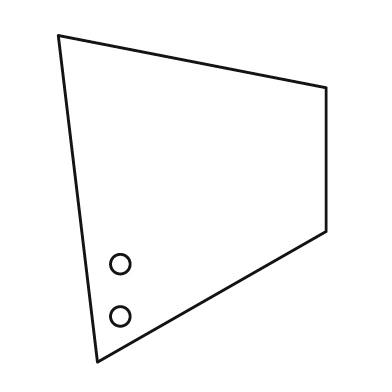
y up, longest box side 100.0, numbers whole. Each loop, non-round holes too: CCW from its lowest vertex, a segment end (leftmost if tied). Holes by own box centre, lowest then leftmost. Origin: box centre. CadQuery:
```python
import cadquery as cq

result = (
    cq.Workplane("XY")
    .moveTo(-29.0, -50.0)
    .lineTo(41.0, -10.0)
    .lineTo(41.0, 34.0)
    .lineTo(-41.0, 50.0)
    .close()
    .moveTo(-22.0, -36.0)
    .circle(3.0)
    .moveTo(-22.0, -20.0)
    .circle(3.0)
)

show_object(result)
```